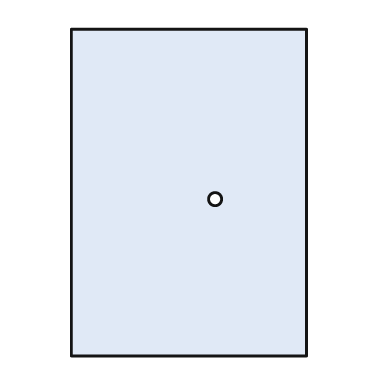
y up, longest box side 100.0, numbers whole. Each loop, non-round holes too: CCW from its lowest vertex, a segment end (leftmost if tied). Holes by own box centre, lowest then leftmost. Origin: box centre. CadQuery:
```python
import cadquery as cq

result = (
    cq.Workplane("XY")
    .moveTo(-36.0, -50.0)
    .lineTo(36.0, -50.0)
    .lineTo(36.0, 50.0)
    .lineTo(-36.0, 50.0)
    .close()
    .moveTo(8.0, -2.0)
    .circle(2.0)
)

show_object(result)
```